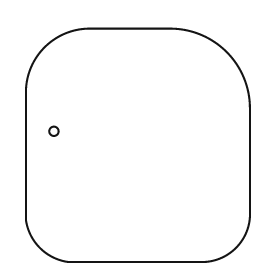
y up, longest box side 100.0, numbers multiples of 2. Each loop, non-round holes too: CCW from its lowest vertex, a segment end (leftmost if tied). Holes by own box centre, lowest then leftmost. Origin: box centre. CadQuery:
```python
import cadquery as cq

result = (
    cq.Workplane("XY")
    .moveTo(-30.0, -50.0)
    .lineTo(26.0, -50.0)
    .threePointArc((42.0, -44.0), (48.0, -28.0))
    .lineTo(48.0, 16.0)
    .threePointArc((38.0, 40.0), (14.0, 50.0))
    .lineTo(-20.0, 50.0)
    .threePointArc((-40.0, 42.0), (-48.0, 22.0))
    .lineTo(-48.0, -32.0)
    .threePointArc((-42.0, -44.0), (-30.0, -50.0))
    .close()
    .moveTo(-36.0, 6.0)
    .circle(2.0)
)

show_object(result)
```